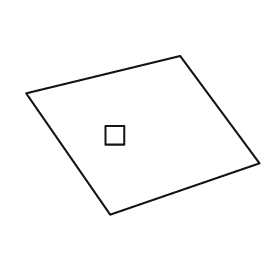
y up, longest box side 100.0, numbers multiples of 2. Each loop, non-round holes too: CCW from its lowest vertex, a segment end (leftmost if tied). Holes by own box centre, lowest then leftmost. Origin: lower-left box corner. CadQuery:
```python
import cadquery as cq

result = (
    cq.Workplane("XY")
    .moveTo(36.0, 0.0)
    .lineTo(100.0, 22.0)
    .lineTo(66.0, 68.0)
    .lineTo(0.0, 52.0)
    .close()
    .moveTo(34.0, 30.0)
    .lineTo(42.0, 30.0)
    .lineTo(42.0, 38.0)
    .lineTo(34.0, 38.0)
    .close()
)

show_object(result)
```